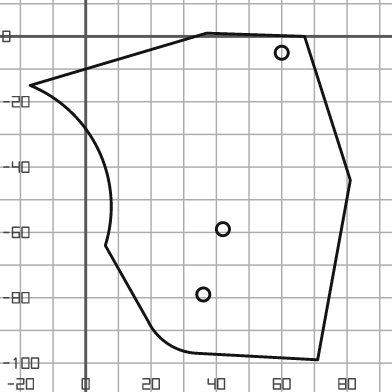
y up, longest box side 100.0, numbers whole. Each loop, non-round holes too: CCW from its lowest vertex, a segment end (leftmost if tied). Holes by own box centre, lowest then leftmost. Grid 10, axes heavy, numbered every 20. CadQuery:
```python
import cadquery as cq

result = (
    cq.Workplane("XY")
    .moveTo(71.0, -99.0)
    .lineTo(81.0, -44.0)
    .lineTo(67.0, 0.0)
    .lineTo(37.0, 1.0)
    .lineTo(-17.0, -15.0)
    .threePointArc((4.0, -35.0), (6.0, -64.0))
    .lineTo(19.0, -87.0)
    .threePointArc((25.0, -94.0), (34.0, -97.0))
    .close()
    .moveTo(36.0, -79.0)
    .circle(2.0)
    .moveTo(42.0, -59.0)
    .circle(2.0)
    .moveTo(60.0, -5.0)
    .circle(2.0)
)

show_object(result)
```